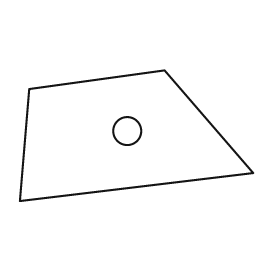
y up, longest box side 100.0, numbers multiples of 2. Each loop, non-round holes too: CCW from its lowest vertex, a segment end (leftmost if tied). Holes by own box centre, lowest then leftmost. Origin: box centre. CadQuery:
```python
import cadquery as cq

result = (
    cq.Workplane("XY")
    .moveTo(-50.0, -28.0)
    .lineTo(50.0, -16.0)
    .lineTo(12.0, 28.0)
    .lineTo(-46.0, 20.0)
    .close()
    .moveTo(-4.0, 2.0)
    .circle(6.0)
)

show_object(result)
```